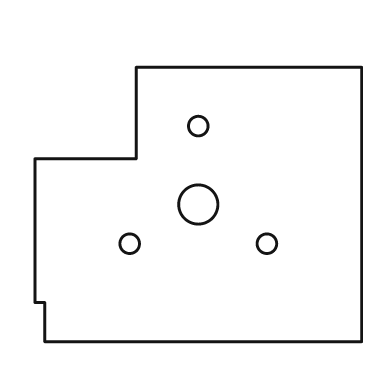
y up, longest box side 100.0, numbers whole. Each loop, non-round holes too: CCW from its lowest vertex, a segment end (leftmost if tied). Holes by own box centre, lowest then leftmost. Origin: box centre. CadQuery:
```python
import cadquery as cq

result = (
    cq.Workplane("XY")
    .moveTo(-47.0, -42.0)
    .lineTo(50.0, -42.0)
    .lineTo(50.0, 42.0)
    .lineTo(-19.0, 42.0)
    .lineTo(-19.0, 14.0)
    .lineTo(-50.0, 14.0)
    .lineTo(-50.0, -30.0)
    .lineTo(-47.0, -30.0)
    .close()
    .moveTo(-21.0, -12.0)
    .circle(3.0)
    .moveTo(21.0, -12.0)
    .circle(3.0)
    .moveTo(0.0, 0.0)
    .circle(6.0)
    .moveTo(0.0, 24.0)
    .circle(3.0)
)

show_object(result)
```